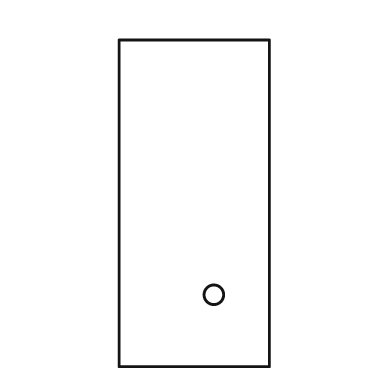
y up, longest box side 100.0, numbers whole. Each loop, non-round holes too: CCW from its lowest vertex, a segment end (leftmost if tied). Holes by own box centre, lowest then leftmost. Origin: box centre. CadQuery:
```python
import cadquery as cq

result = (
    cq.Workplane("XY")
    .moveTo(-23.0, -50.0)
    .lineTo(23.0, -50.0)
    .lineTo(23.0, 50.0)
    .lineTo(-23.0, 50.0)
    .close()
    .moveTo(6.0, -28.0)
    .circle(3.0)
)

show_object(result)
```